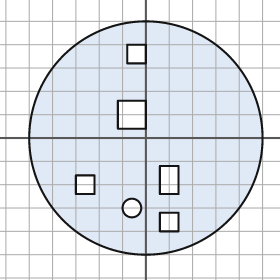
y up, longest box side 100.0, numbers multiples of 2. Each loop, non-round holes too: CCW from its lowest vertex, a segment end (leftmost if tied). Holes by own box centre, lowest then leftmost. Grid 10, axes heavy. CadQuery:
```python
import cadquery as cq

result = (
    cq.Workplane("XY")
    .moveTo(0.0, 0.0)
    .circle(50.0)
    .moveTo(6.0, -40.0)
    .lineTo(14.0, -40.0)
    .lineTo(14.0, -32.0)
    .lineTo(6.0, -32.0)
    .close()
    .moveTo(-6.0, -30.0)
    .circle(4.0)
    .moveTo(-30.0, -24.0)
    .lineTo(-22.0, -24.0)
    .lineTo(-22.0, -16.0)
    .lineTo(-30.0, -16.0)
    .close()
    .moveTo(6.0, -24.0)
    .lineTo(14.0, -24.0)
    .lineTo(14.0, -12.0)
    .lineTo(6.0, -12.0)
    .close()
    .moveTo(-12.0, 4.0)
    .lineTo(0.0, 4.0)
    .lineTo(0.0, 16.0)
    .lineTo(-12.0, 16.0)
    .close()
    .moveTo(-8.0, 32.0)
    .lineTo(0.0, 32.0)
    .lineTo(0.0, 40.0)
    .lineTo(-8.0, 40.0)
    .close()
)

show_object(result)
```